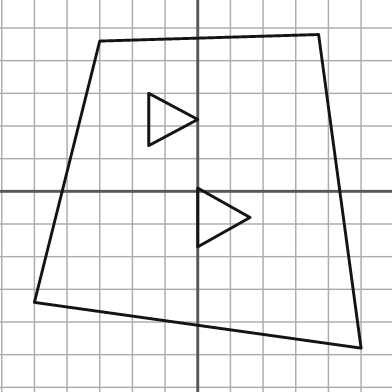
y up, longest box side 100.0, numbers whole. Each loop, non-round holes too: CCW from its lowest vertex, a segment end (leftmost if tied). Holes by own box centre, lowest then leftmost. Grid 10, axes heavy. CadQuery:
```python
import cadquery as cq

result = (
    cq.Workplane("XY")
    .moveTo(50.0, -48.0)
    .lineTo(37.0, 48.0)
    .lineTo(-30.0, 46.0)
    .lineTo(-50.0, -34.0)
    .close()
    .moveTo(0.0, -17.0)
    .lineTo(16.0, -8.0)
    .lineTo(0.0, 1.0)
    .close()
    .moveTo(-15.0, 14.0)
    .lineTo(0.0, 22.0)
    .lineTo(-15.0, 30.0)
    .close()
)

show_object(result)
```